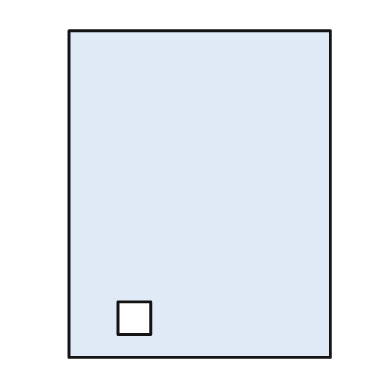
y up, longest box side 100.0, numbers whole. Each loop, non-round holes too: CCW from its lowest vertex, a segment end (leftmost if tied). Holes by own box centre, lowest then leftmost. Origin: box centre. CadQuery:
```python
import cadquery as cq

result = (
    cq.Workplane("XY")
    .moveTo(-40.0, -50.0)
    .lineTo(40.0, -50.0)
    .lineTo(40.0, 50.0)
    .lineTo(-40.0, 50.0)
    .close()
    .moveTo(-25.0, -43.0)
    .lineTo(-15.0, -43.0)
    .lineTo(-15.0, -33.0)
    .lineTo(-25.0, -33.0)
    .close()
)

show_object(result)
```